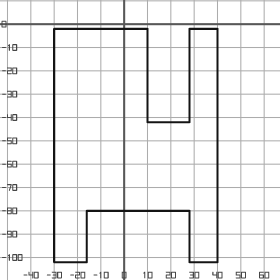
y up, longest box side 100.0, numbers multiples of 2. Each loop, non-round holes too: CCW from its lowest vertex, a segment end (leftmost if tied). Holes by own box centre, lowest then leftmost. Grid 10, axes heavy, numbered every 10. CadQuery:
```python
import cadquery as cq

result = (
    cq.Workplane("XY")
    .moveTo(-30.0, -102.0)
    .lineTo(-16.0, -102.0)
    .lineTo(-16.0, -80.0)
    .lineTo(28.0, -80.0)
    .lineTo(28.0, -102.0)
    .lineTo(40.0, -102.0)
    .lineTo(40.0, -2.0)
    .lineTo(28.0, -2.0)
    .lineTo(28.0, -42.0)
    .lineTo(10.0, -42.0)
    .lineTo(10.0, -2.0)
    .lineTo(-30.0, -2.0)
    .close()
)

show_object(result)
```